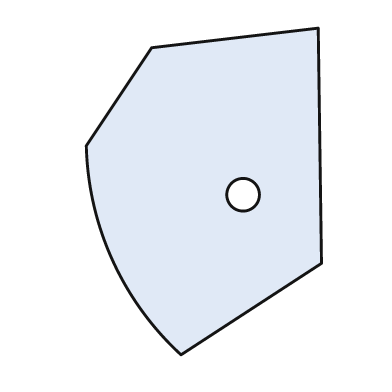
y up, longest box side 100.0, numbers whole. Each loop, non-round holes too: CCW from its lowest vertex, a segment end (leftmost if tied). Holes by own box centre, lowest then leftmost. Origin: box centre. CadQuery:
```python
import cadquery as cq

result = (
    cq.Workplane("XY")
    .moveTo(-7.0, -50.0)
    .lineTo(36.0, -22.0)
    .lineTo(35.0, 50.0)
    .lineTo(-16.0, 44.0)
    .lineTo(-36.0, 14.0)
    .threePointArc((-28.0, -21.0), (-7.0, -50.0))
    .close()
    .moveTo(12.0, -1.0)
    .circle(5.0)
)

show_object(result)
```